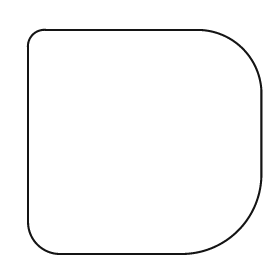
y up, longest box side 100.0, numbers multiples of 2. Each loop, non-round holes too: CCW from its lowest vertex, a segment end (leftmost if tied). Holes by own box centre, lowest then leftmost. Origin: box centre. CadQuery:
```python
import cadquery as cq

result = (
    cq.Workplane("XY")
    .moveTo(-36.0, -48.0)
    .lineTo(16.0, -48.0)
    .threePointArc((40.0, -38.0), (50.0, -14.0))
    .lineTo(50.0, 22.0)
    .threePointArc((42.0, 40.0), (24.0, 48.0))
    .lineTo(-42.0, 48.0)
    .threePointArc((-48.0, 46.0), (-50.0, 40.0))
    .lineTo(-50.0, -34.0)
    .threePointArc((-46.0, -44.0), (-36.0, -48.0))
    .close()
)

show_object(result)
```